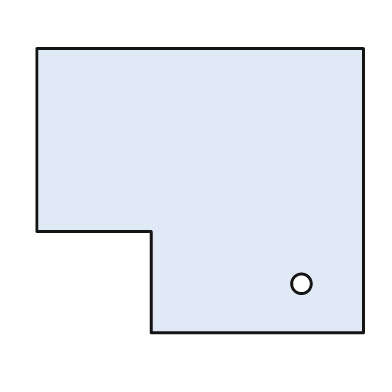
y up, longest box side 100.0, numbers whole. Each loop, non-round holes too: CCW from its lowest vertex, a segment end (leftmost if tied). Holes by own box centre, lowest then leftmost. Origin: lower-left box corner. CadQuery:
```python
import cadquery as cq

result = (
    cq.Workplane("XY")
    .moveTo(35.0, 0.0)
    .lineTo(100.0, 0.0)
    .lineTo(100.0, 87.0)
    .lineTo(0.0, 87.0)
    .lineTo(0.0, 31.0)
    .lineTo(35.0, 31.0)
    .close()
    .moveTo(81.0, 15.0)
    .circle(3.0)
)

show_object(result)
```